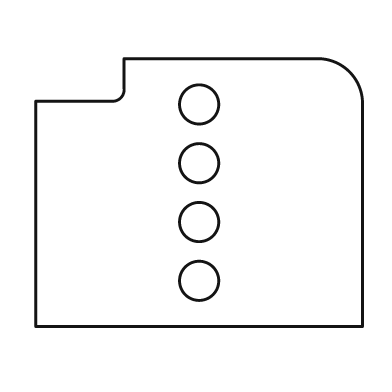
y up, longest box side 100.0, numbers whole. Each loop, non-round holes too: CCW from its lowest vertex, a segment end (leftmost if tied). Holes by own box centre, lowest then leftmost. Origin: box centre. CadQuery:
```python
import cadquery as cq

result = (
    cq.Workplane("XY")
    .moveTo(-50.0, -41.0)
    .lineTo(50.0, -41.0)
    .lineTo(50.0, 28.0)
    .threePointArc((46.0, 37.0), (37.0, 41.0))
    .lineTo(-23.0, 41.0)
    .lineTo(-23.0, 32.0)
    .threePointArc((-24.0, 29.0), (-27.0, 28.0))
    .lineTo(-50.0, 28.0)
    .close()
    .moveTo(0.0, -27.0)
    .circle(6.0)
    .moveTo(0.0, -9.0)
    .circle(6.0)
    .moveTo(0.0, 9.0)
    .circle(6.0)
    .moveTo(0.0, 27.0)
    .circle(6.0)
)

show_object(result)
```